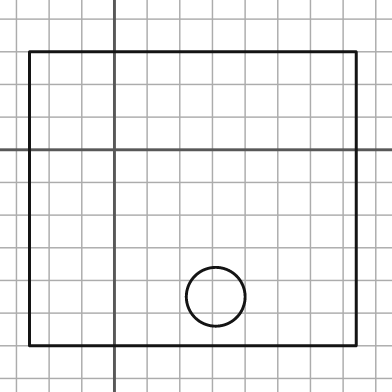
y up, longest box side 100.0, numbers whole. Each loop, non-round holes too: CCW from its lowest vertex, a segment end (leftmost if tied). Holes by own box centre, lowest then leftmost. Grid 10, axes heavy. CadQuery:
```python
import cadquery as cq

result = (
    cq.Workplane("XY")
    .moveTo(-26.0, -60.0)
    .lineTo(74.0, -60.0)
    .lineTo(74.0, 30.0)
    .lineTo(-26.0, 30.0)
    .close()
    .moveTo(31.0, -45.0)
    .circle(9.0)
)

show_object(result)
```